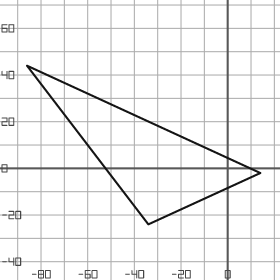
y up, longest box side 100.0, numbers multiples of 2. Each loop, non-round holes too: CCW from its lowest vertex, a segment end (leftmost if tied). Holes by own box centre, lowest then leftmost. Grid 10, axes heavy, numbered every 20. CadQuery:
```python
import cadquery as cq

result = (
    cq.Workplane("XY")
    .moveTo(-34.0, -24.0)
    .lineTo(14.0, -2.0)
    .lineTo(-86.0, 44.0)
    .close()
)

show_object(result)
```